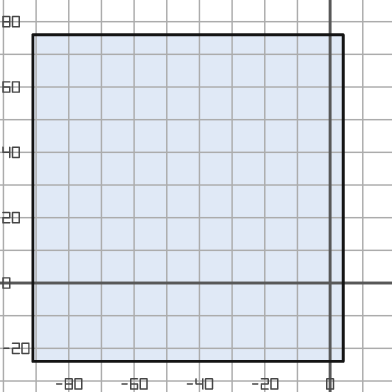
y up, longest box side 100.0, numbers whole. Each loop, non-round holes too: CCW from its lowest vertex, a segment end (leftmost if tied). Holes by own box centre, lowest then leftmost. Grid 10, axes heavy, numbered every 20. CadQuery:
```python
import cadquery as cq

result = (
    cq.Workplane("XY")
    .moveTo(-91.0, -24.0)
    .lineTo(4.0, -24.0)
    .lineTo(4.0, 76.0)
    .lineTo(-91.0, 76.0)
    .close()
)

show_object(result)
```